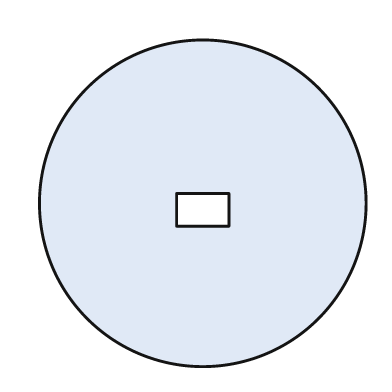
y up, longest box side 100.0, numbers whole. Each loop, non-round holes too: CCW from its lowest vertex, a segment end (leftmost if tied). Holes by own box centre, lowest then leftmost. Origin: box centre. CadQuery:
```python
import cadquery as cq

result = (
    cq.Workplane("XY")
    .moveTo(0.0, 0.0)
    .circle(50.0)
    .moveTo(-8.0, -7.0)
    .lineTo(8.0, -7.0)
    .lineTo(8.0, 3.0)
    .lineTo(-8.0, 3.0)
    .close()
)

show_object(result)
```